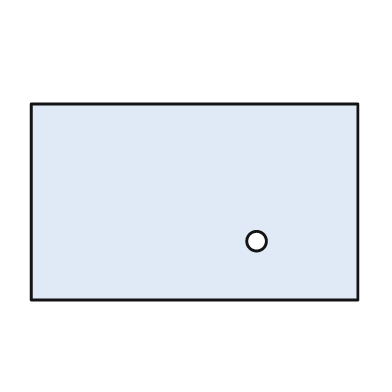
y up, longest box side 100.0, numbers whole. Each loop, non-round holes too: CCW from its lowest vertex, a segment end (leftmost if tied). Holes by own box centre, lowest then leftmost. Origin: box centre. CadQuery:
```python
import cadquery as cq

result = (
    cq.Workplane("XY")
    .moveTo(-50.0, -30.0)
    .lineTo(50.0, -30.0)
    .lineTo(50.0, 30.0)
    .lineTo(-50.0, 30.0)
    .close()
    .moveTo(19.0, -12.0)
    .circle(3.0)
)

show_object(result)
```